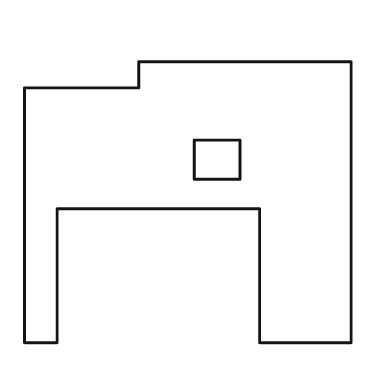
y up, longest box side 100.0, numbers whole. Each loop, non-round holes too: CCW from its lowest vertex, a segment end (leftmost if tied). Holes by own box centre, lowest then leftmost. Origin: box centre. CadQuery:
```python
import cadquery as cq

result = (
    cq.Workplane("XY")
    .moveTo(-50.0, -43.0)
    .lineTo(-40.0, -43.0)
    .lineTo(-40.0, -2.0)
    .lineTo(22.0, -2.0)
    .lineTo(22.0, -43.0)
    .lineTo(50.0, -43.0)
    .lineTo(50.0, 43.0)
    .lineTo(-15.0, 43.0)
    .lineTo(-15.0, 35.0)
    .lineTo(-50.0, 35.0)
    .close()
    .moveTo(2.0, 7.0)
    .lineTo(16.0, 7.0)
    .lineTo(16.0, 19.0)
    .lineTo(2.0, 19.0)
    .close()
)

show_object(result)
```